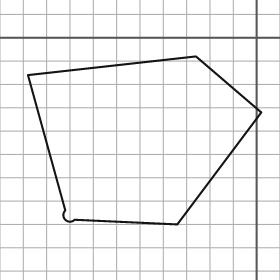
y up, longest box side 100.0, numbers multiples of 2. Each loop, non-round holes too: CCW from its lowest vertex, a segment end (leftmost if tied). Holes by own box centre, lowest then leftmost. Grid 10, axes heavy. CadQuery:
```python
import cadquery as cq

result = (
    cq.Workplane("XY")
    .moveTo(-34.0, -80.0)
    .lineTo(2.0, -32.0)
    .lineTo(-26.0, -8.0)
    .lineTo(-98.0, -16.0)
    .lineTo(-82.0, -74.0)
    .threePointArc((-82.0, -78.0), (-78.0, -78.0))
    .close()
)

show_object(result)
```